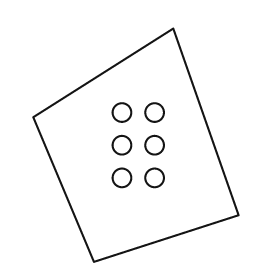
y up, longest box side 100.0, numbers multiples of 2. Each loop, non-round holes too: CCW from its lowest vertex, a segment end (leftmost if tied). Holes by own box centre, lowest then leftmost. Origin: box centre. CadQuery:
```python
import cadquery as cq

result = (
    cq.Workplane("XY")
    .moveTo(-18.0, -50.0)
    .lineTo(44.0, -30.0)
    .lineTo(16.0, 50.0)
    .lineTo(-44.0, 12.0)
    .close()
    .moveTo(-6.0, -14.0)
    .circle(4.0)
    .moveTo(8.0, -14.0)
    .circle(4.0)
    .moveTo(-6.0, 0.0)
    .circle(4.0)
    .moveTo(8.0, 0.0)
    .circle(4.0)
    .moveTo(-6.0, 14.0)
    .circle(4.0)
    .moveTo(8.0, 14.0)
    .circle(4.0)
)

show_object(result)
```